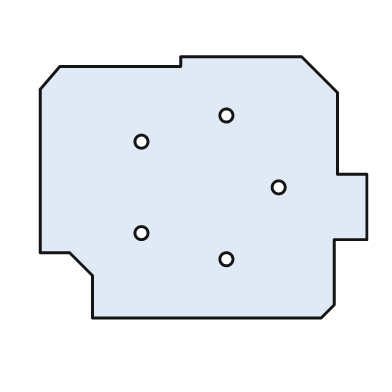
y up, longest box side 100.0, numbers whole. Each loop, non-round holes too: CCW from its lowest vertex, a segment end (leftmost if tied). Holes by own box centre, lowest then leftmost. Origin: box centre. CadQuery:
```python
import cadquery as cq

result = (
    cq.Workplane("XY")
    .moveTo(-34.0, -40.0)
    .lineTo(36.0, -40.0)
    .lineTo(40.0, -36.0)
    .lineTo(40.0, -16.0)
    .lineTo(50.0, -16.0)
    .lineTo(50.0, 4.0)
    .lineTo(41.0, 4.0)
    .lineTo(41.0, 29.0)
    .lineTo(30.0, 40.0)
    .lineTo(-7.0, 40.0)
    .lineTo(-7.0, 37.0)
    .lineTo(-44.0, 37.0)
    .lineTo(-50.0, 30.0)
    .lineTo(-50.0, -20.0)
    .lineTo(-41.0, -20.0)
    .lineTo(-34.0, -27.0)
    .close()
    .moveTo(7.0, -22.0)
    .circle(2.0)
    .moveTo(-19.0, -14.0)
    .circle(2.0)
    .moveTo(23.0, 0.0)
    .circle(2.0)
    .moveTo(-19.0, 14.0)
    .circle(2.0)
    .moveTo(7.0, 22.0)
    .circle(2.0)
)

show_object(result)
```